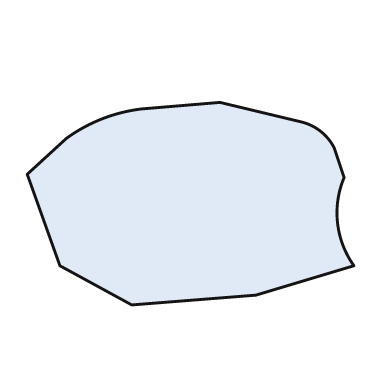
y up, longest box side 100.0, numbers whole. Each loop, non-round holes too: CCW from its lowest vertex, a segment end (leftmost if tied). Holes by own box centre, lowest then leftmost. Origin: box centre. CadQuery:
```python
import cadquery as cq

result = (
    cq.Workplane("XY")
    .moveTo(-18.0, -31.0)
    .lineTo(20.0, -28.0)
    .lineTo(50.0, -19.0)
    .threePointArc((45.0, -6.0), (47.0, 8.0))
    .lineTo(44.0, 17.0)
    .threePointArc((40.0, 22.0), (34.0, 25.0))
    .lineTo(9.0, 31.0)
    .lineTo(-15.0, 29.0)
    .threePointArc((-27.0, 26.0), (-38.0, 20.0))
    .lineTo(-50.0, 9.0)
    .lineTo(-40.0, -19.0)
    .close()
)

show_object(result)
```